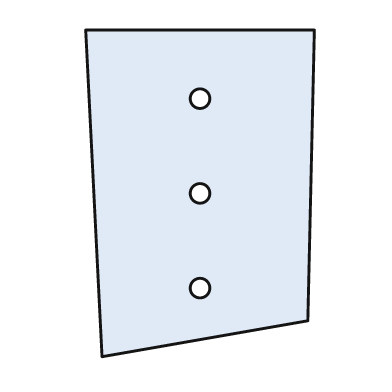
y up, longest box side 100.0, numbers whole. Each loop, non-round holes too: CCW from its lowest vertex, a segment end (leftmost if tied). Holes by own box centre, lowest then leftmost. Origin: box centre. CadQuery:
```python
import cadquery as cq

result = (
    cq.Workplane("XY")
    .moveTo(-30.0, -50.0)
    .lineTo(33.0, -39.0)
    .lineTo(35.0, 50.0)
    .lineTo(-35.0, 50.0)
    .close()
    .moveTo(0.0, -29.0)
    .circle(3.0)
    .moveTo(0.0, 0.0)
    .circle(3.0)
    .moveTo(0.0, 29.0)
    .circle(3.0)
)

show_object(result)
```